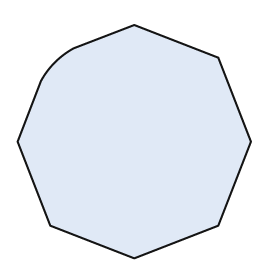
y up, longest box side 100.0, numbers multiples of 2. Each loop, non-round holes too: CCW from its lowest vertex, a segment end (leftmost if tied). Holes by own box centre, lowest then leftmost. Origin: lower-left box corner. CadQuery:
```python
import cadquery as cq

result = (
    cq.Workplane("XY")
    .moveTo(50.0, 0.0)
    .lineTo(86.0, 14.0)
    .lineTo(100.0, 50.0)
    .lineTo(86.0, 86.0)
    .lineTo(50.0, 100.0)
    .lineTo(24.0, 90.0)
    .threePointArc((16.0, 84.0), (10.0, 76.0))
    .lineTo(0.0, 50.0)
    .lineTo(14.0, 14.0)
    .close()
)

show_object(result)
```